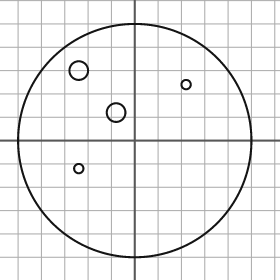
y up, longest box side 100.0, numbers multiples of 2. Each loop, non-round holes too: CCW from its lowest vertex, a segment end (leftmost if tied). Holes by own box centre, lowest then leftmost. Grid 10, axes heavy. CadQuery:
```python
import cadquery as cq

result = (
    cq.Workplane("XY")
    .moveTo(0.0, 0.0)
    .circle(50.0)
    .moveTo(-24.0, -12.0)
    .circle(2.0)
    .moveTo(-8.0, 12.0)
    .circle(4.0)
    .moveTo(22.0, 24.0)
    .circle(2.0)
    .moveTo(-24.0, 30.0)
    .circle(4.0)
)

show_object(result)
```